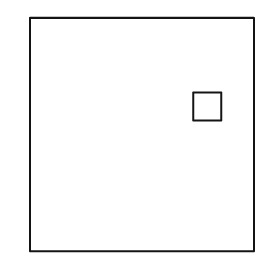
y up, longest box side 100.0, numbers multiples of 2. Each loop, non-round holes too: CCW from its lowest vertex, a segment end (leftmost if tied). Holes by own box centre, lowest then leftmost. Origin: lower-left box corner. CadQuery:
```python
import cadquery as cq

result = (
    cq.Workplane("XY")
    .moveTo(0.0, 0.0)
    .lineTo(96.0, 0.0)
    .lineTo(96.0, 100.0)
    .lineTo(0.0, 100.0)
    .close()
    .moveTo(70.0, 56.0)
    .lineTo(82.0, 56.0)
    .lineTo(82.0, 68.0)
    .lineTo(70.0, 68.0)
    .close()
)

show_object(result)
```